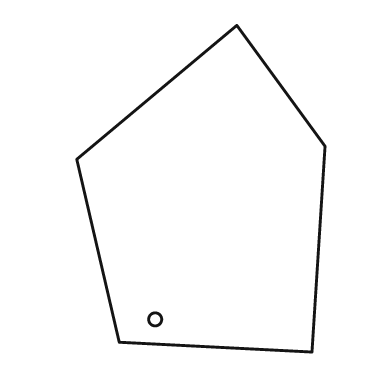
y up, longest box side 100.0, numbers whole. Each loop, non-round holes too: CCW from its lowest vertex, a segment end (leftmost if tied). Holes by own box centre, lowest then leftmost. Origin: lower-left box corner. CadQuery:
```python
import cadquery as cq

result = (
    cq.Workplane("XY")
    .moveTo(72.0, 0.0)
    .lineTo(76.0, 63.0)
    .lineTo(49.0, 100.0)
    .lineTo(0.0, 59.0)
    .lineTo(13.0, 3.0)
    .close()
    .moveTo(24.0, 10.0)
    .circle(2.0)
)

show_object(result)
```